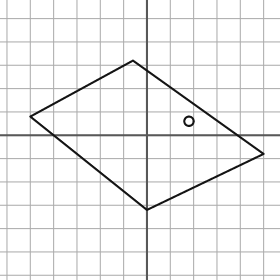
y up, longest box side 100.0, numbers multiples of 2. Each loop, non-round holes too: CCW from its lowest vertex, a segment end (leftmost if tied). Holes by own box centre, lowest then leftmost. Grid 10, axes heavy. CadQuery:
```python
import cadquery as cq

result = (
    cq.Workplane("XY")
    .moveTo(0.0, -32.0)
    .lineTo(50.0, -8.0)
    .lineTo(-6.0, 32.0)
    .lineTo(-50.0, 8.0)
    .close()
    .moveTo(18.0, 6.0)
    .circle(2.0)
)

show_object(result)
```